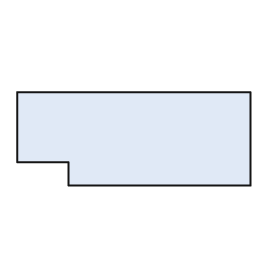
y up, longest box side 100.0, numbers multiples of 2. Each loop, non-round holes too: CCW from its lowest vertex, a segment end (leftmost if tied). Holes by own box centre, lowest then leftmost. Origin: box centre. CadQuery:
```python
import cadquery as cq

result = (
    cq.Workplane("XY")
    .moveTo(-28.0, -20.0)
    .lineTo(50.0, -20.0)
    .lineTo(50.0, 20.0)
    .lineTo(-50.0, 20.0)
    .lineTo(-50.0, -10.0)
    .lineTo(-28.0, -10.0)
    .close()
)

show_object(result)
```